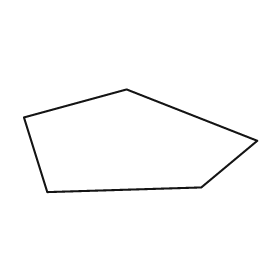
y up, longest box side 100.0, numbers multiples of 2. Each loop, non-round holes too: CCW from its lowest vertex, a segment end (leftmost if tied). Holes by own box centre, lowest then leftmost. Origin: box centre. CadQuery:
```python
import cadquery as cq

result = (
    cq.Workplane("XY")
    .moveTo(-40.0, -22.0)
    .lineTo(26.0, -20.0)
    .lineTo(50.0, 0.0)
    .lineTo(-6.0, 22.0)
    .lineTo(-50.0, 10.0)
    .close()
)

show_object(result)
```